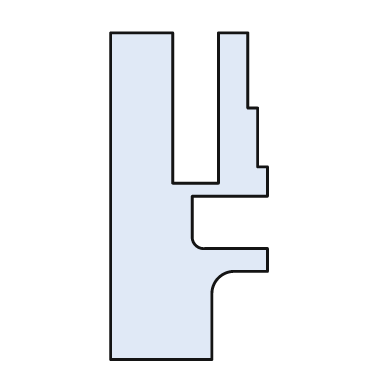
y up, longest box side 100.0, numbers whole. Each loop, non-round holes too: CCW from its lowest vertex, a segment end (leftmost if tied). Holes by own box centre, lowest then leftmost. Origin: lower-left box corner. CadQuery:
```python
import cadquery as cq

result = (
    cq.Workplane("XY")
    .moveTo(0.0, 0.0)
    .lineTo(31.0, 0.0)
    .lineTo(31.0, 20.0)
    .threePointArc((33.0, 25.0), (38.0, 27.0))
    .lineTo(48.0, 27.0)
    .lineTo(48.0, 34.0)
    .lineTo(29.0, 34.0)
    .threePointArc((26.0, 35.0), (25.0, 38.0))
    .lineTo(25.0, 50.0)
    .lineTo(48.0, 50.0)
    .lineTo(48.0, 59.0)
    .lineTo(45.0, 59.0)
    .lineTo(45.0, 77.0)
    .lineTo(42.0, 77.0)
    .lineTo(42.0, 100.0)
    .lineTo(33.0, 100.0)
    .lineTo(33.0, 54.0)
    .lineTo(19.0, 54.0)
    .lineTo(19.0, 100.0)
    .lineTo(0.0, 100.0)
    .close()
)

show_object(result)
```